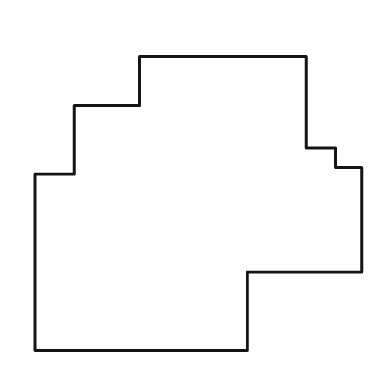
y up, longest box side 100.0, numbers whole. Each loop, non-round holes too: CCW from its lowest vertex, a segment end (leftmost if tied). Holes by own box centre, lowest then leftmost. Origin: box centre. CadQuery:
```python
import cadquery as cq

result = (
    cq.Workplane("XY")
    .moveTo(-50.0, -45.0)
    .lineTo(15.0, -45.0)
    .lineTo(15.0, -21.0)
    .lineTo(50.0, -21.0)
    .lineTo(50.0, 11.0)
    .lineTo(42.0, 11.0)
    .lineTo(42.0, 17.0)
    .lineTo(33.0, 17.0)
    .lineTo(33.0, 45.0)
    .lineTo(-18.0, 45.0)
    .lineTo(-18.0, 30.0)
    .lineTo(-38.0, 30.0)
    .lineTo(-38.0, 9.0)
    .lineTo(-50.0, 9.0)
    .close()
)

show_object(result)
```